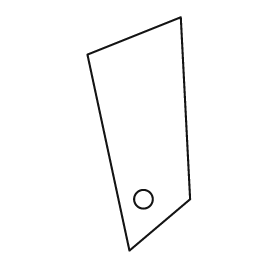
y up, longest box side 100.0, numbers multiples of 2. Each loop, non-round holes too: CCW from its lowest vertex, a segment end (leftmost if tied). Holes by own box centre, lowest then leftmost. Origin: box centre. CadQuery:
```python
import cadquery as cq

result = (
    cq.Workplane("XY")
    .moveTo(-4.0, -50.0)
    .lineTo(22.0, -28.0)
    .lineTo(18.0, 50.0)
    .lineTo(-22.0, 34.0)
    .close()
    .moveTo(2.0, -28.0)
    .circle(4.0)
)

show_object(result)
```